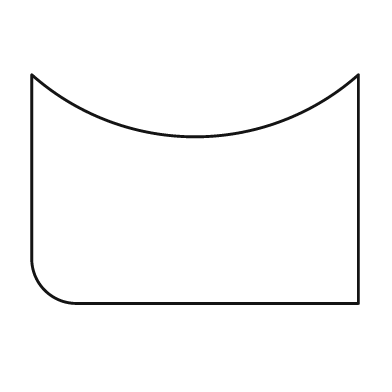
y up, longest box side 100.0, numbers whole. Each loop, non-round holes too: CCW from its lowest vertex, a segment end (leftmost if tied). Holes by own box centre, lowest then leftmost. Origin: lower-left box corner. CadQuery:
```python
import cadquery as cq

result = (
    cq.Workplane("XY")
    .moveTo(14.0, 0.0)
    .lineTo(100.0, 0.0)
    .lineTo(100.0, 70.0)
    .threePointArc((50.0, 51.0), (0.0, 70.0))
    .lineTo(0.0, 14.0)
    .threePointArc((4.0, 4.0), (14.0, 0.0))
    .close()
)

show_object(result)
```